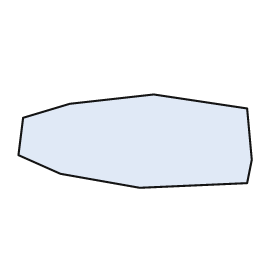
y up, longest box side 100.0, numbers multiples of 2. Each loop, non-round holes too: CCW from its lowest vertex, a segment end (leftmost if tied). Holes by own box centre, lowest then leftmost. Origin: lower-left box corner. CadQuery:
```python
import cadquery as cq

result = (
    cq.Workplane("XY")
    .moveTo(52.0, 0.0)
    .lineTo(98.0, 2.0)
    .lineTo(100.0, 12.0)
    .lineTo(98.0, 34.0)
    .lineTo(58.0, 40.0)
    .lineTo(22.0, 36.0)
    .lineTo(2.0, 30.0)
    .lineTo(0.0, 14.0)
    .lineTo(18.0, 6.0)
    .close()
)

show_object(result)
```